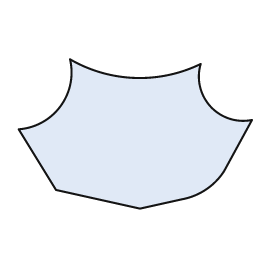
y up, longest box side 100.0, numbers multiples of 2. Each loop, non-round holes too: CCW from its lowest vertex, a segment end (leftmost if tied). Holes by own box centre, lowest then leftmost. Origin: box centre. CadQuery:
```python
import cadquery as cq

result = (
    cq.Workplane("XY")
    .moveTo(2.0, -32.0)
    .lineTo(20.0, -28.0)
    .threePointArc((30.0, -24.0), (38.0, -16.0))
    .lineTo(50.0, 6.0)
    .threePointArc((32.0, 12.0), (28.0, 30.0))
    .threePointArc((0.0, 24.0), (-28.0, 32.0))
    .threePointArc((-32.0, 12.0), (-50.0, 2.0))
    .lineTo(-34.0, -24.0)
    .close()
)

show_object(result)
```